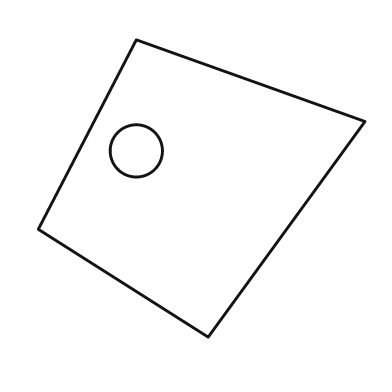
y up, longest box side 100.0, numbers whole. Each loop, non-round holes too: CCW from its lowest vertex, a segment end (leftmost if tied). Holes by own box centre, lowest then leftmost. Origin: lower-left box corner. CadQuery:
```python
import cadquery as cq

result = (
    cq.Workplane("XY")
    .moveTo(52.0, 0.0)
    .lineTo(100.0, 66.0)
    .lineTo(30.0, 91.0)
    .lineTo(0.0, 33.0)
    .close()
    .moveTo(30.0, 57.0)
    .circle(8.0)
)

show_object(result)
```